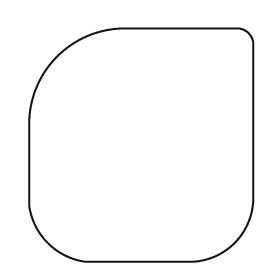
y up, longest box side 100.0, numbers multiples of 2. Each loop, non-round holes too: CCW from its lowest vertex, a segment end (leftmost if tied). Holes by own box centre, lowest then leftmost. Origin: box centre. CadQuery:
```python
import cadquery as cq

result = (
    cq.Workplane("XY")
    .moveTo(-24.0, -50.0)
    .lineTo(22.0, -50.0)
    .threePointArc((40.0, -42.0), (48.0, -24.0))
    .lineTo(48.0, 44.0)
    .threePointArc((46.0, 48.0), (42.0, 50.0))
    .lineTo(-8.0, 50.0)
    .threePointArc((-36.0, 38.0), (-48.0, 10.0))
    .lineTo(-48.0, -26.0)
    .threePointArc((-40.0, -42.0), (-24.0, -50.0))
    .close()
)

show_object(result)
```